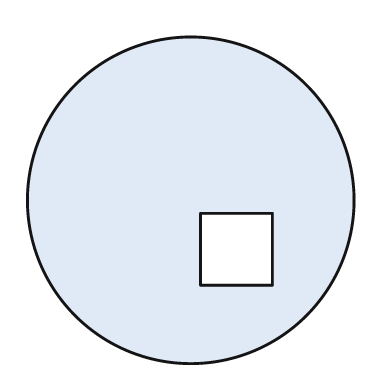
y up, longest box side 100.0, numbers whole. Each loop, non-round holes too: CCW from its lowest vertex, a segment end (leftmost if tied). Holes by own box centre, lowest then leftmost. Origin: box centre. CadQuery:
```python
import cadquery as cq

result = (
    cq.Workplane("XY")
    .moveTo(0.0, 0.0)
    .circle(50.0)
    .moveTo(3.0, -26.0)
    .lineTo(25.0, -26.0)
    .lineTo(25.0, -4.0)
    .lineTo(3.0, -4.0)
    .close()
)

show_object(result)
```